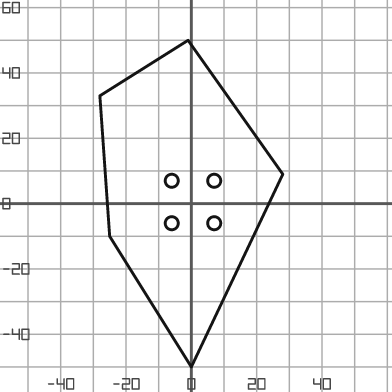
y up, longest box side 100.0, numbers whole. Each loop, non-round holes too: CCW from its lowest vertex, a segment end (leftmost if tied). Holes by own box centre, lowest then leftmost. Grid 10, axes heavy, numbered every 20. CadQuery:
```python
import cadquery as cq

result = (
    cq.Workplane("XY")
    .moveTo(0.0, -50.0)
    .lineTo(28.0, 9.0)
    .lineTo(-1.0, 50.0)
    .lineTo(-28.0, 33.0)
    .lineTo(-25.0, -10.0)
    .close()
    .moveTo(-6.0, -6.0)
    .circle(2.0)
    .moveTo(7.0, -6.0)
    .circle(2.0)
    .moveTo(-6.0, 7.0)
    .circle(2.0)
    .moveTo(7.0, 7.0)
    .circle(2.0)
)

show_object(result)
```